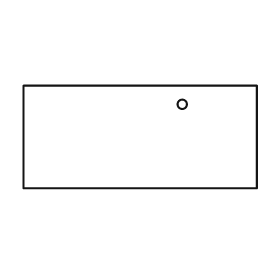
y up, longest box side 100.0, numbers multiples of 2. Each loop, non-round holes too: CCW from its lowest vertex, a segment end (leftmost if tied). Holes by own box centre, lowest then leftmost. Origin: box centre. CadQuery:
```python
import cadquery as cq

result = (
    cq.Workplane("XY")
    .moveTo(-50.0, -22.0)
    .lineTo(50.0, -22.0)
    .lineTo(50.0, 22.0)
    .lineTo(-50.0, 22.0)
    .close()
    .moveTo(18.0, 14.0)
    .circle(2.0)
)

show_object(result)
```